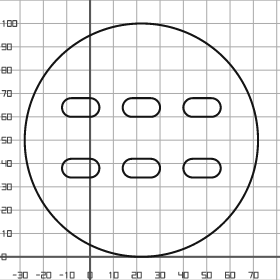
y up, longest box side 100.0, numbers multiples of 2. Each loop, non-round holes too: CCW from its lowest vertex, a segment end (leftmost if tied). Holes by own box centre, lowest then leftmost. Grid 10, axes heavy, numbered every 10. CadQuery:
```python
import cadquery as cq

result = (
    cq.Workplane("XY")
    .moveTo(22.0, 50.0)
    .circle(50.0)
    .moveTo(-8.0, 34.0)
    .lineTo(0.0, 34.0)
    .threePointArc((4.0, 38.0), (0.0, 42.0))
    .lineTo(-8.0, 42.0)
    .threePointArc((-12.0, 38.0), (-8.0, 34.0))
    .close()
    .moveTo(18.0, 34.0)
    .lineTo(26.0, 34.0)
    .threePointArc((30.0, 38.0), (26.0, 42.0))
    .lineTo(18.0, 42.0)
    .threePointArc((14.0, 38.0), (18.0, 34.0))
    .close()
    .moveTo(44.0, 34.0)
    .lineTo(52.0, 34.0)
    .threePointArc((56.0, 38.0), (52.0, 42.0))
    .lineTo(44.0, 42.0)
    .threePointArc((40.0, 38.0), (44.0, 34.0))
    .close()
    .moveTo(-8.0, 60.0)
    .lineTo(0.0, 60.0)
    .threePointArc((4.0, 64.0), (0.0, 68.0))
    .lineTo(-8.0, 68.0)
    .threePointArc((-12.0, 64.0), (-8.0, 60.0))
    .close()
    .moveTo(18.0, 60.0)
    .lineTo(26.0, 60.0)
    .threePointArc((30.0, 64.0), (26.0, 68.0))
    .lineTo(18.0, 68.0)
    .threePointArc((14.0, 64.0), (18.0, 60.0))
    .close()
    .moveTo(44.0, 60.0)
    .lineTo(52.0, 60.0)
    .threePointArc((56.0, 64.0), (52.0, 68.0))
    .lineTo(44.0, 68.0)
    .threePointArc((40.0, 64.0), (44.0, 60.0))
    .close()
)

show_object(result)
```